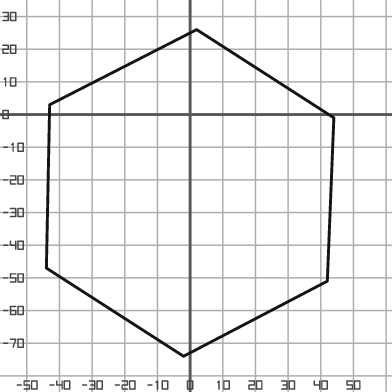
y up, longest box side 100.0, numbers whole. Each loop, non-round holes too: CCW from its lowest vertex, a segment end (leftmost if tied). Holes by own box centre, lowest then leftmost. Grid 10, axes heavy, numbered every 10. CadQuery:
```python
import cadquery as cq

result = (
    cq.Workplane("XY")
    .moveTo(-2.0, -74.0)
    .lineTo(42.0, -51.0)
    .lineTo(44.0, -1.0)
    .lineTo(2.0, 26.0)
    .lineTo(-43.0, 3.0)
    .lineTo(-44.0, -47.0)
    .close()
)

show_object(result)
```